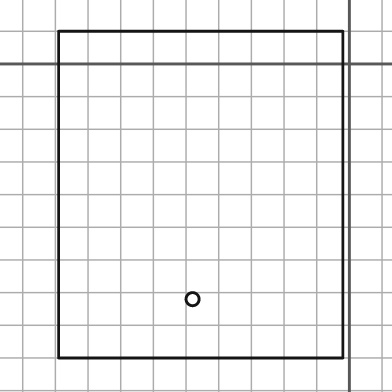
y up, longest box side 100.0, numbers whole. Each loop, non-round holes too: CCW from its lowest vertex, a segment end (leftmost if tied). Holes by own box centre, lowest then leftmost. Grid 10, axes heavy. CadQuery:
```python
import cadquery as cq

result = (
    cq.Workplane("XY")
    .moveTo(-89.0, -90.0)
    .lineTo(-2.0, -90.0)
    .lineTo(-2.0, 10.0)
    .lineTo(-89.0, 10.0)
    .close()
    .moveTo(-48.0, -72.0)
    .circle(2.0)
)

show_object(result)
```